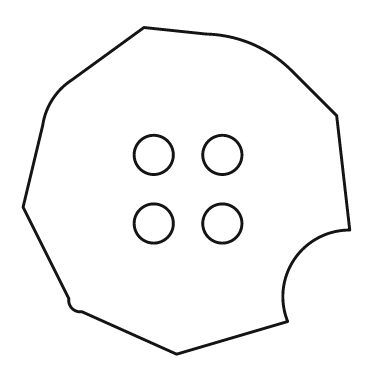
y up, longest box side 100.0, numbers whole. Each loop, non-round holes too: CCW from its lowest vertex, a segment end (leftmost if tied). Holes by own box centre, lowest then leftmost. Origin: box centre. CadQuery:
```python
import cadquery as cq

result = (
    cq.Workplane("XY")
    .moveTo(-3.0, -50.0)
    .lineTo(31.0, -40.0)
    .threePointArc((33.0, -21.0), (50.0, -12.0))
    .lineTo(46.0, 23.0)
    .lineTo(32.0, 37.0)
    .threePointArc((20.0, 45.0), (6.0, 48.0))
    .lineTo(-13.0, 50.0)
    .lineTo(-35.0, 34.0)
    .threePointArc((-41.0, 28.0), (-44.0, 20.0))
    .lineTo(-50.0, -5.0)
    .lineTo(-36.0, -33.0)
    .threePointArc((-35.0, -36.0), (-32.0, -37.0))
    .close()
    .moveTo(-10.0, -10.0)
    .circle(6.0)
    .moveTo(11.0, -10.0)
    .circle(6.0)
    .moveTo(-10.0, 11.0)
    .circle(6.0)
    .moveTo(11.0, 11.0)
    .circle(6.0)
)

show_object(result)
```